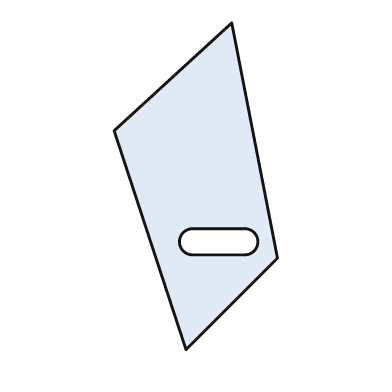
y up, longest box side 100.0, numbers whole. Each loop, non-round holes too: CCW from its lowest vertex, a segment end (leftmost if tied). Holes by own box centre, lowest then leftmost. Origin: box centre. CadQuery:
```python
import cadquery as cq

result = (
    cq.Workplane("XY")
    .moveTo(-3.0, -50.0)
    .lineTo(25.0, -22.0)
    .lineTo(11.0, 50.0)
    .lineTo(-25.0, 17.0)
    .close()
    .moveTo(-1.0, -21.0)
    .lineTo(15.0, -21.0)
    .threePointArc((19.0, -17.0), (15.0, -13.0))
    .lineTo(-1.0, -13.0)
    .threePointArc((-5.0, -17.0), (-1.0, -21.0))
    .close()
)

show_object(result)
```